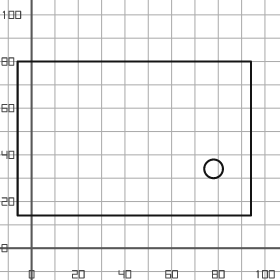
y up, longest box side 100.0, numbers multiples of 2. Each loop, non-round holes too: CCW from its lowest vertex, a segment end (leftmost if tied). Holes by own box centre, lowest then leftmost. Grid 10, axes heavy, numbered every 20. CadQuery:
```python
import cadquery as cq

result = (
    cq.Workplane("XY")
    .moveTo(-6.0, 14.0)
    .lineTo(94.0, 14.0)
    .lineTo(94.0, 80.0)
    .lineTo(-6.0, 80.0)
    .close()
    .moveTo(78.0, 34.0)
    .circle(4.0)
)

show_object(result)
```